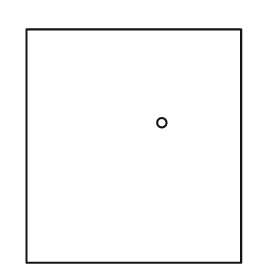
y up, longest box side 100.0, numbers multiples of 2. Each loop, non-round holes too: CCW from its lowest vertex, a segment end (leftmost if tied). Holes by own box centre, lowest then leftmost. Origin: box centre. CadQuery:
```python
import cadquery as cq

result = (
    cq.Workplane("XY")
    .moveTo(-46.0, -50.0)
    .lineTo(46.0, -50.0)
    .lineTo(46.0, 50.0)
    .lineTo(-46.0, 50.0)
    .close()
    .moveTo(12.0, 10.0)
    .circle(2.0)
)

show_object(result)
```